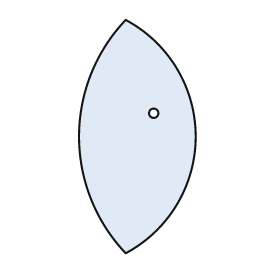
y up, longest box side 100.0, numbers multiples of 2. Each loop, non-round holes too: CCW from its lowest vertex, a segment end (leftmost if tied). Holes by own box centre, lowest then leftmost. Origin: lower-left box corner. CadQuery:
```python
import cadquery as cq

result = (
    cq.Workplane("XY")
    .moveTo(20.0, 0.0)
    .threePointArc((50.0, 50.0), (20.0, 100.0))
    .threePointArc((0.0, 50.0), (20.0, 0.0))
    .close()
    .moveTo(32.0, 60.0)
    .circle(2.0)
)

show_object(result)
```